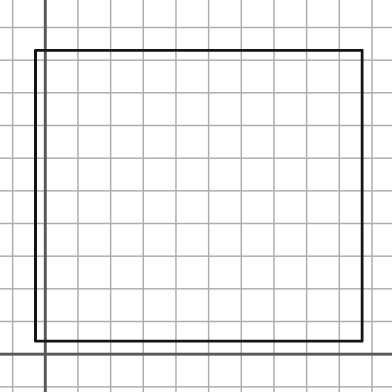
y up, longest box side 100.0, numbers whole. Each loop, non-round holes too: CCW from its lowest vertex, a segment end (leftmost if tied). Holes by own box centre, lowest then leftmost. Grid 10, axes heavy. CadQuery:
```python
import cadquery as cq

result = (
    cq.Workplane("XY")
    .moveTo(-3.0, 4.0)
    .lineTo(97.0, 4.0)
    .lineTo(97.0, 93.0)
    .lineTo(-3.0, 93.0)
    .close()
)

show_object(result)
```